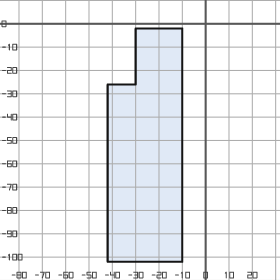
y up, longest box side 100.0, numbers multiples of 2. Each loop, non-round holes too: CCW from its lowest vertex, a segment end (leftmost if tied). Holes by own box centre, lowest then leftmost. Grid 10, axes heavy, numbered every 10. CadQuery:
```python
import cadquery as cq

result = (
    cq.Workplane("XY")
    .moveTo(-42.0, -102.0)
    .lineTo(-10.0, -102.0)
    .lineTo(-10.0, -2.0)
    .lineTo(-30.0, -2.0)
    .lineTo(-30.0, -26.0)
    .lineTo(-42.0, -26.0)
    .close()
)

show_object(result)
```